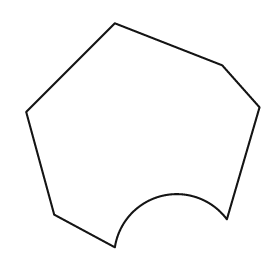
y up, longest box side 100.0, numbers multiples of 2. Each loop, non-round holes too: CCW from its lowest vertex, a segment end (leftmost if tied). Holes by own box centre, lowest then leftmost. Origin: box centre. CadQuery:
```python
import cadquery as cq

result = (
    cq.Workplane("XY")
    .moveTo(-12.0, -48.0)
    .threePointArc((8.0, -26.0), (36.0, -36.0))
    .lineTo(50.0, 12.0)
    .lineTo(34.0, 30.0)
    .lineTo(-12.0, 48.0)
    .lineTo(-50.0, 10.0)
    .lineTo(-38.0, -34.0)
    .close()
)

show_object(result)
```